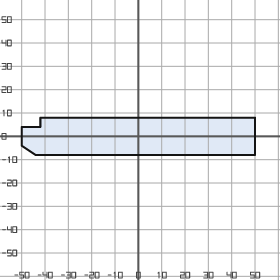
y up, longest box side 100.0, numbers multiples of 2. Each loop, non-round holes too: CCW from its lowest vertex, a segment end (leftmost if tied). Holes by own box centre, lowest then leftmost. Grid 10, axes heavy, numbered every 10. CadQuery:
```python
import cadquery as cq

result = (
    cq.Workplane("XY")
    .moveTo(-44.0, -8.0)
    .lineTo(50.0, -8.0)
    .lineTo(50.0, 8.0)
    .lineTo(-42.0, 8.0)
    .lineTo(-42.0, 4.0)
    .lineTo(-50.0, 4.0)
    .lineTo(-50.0, -4.0)
    .close()
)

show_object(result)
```